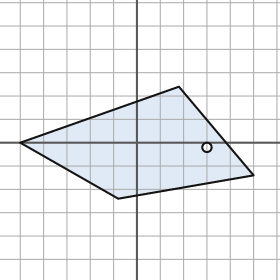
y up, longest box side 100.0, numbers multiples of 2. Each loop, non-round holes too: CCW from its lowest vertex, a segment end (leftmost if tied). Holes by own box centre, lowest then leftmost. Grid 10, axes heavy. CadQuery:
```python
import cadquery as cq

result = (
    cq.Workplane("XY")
    .moveTo(-8.0, -24.0)
    .lineTo(50.0, -14.0)
    .lineTo(18.0, 24.0)
    .lineTo(-50.0, 0.0)
    .close()
    .moveTo(30.0, -2.0)
    .circle(2.0)
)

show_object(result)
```